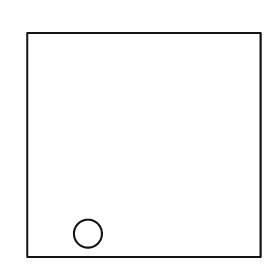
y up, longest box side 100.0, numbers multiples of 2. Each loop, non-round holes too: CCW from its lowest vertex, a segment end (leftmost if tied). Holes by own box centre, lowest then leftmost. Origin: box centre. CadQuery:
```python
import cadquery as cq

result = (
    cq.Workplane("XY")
    .moveTo(-50.0, -48.0)
    .lineTo(50.0, -48.0)
    .lineTo(50.0, 48.0)
    .lineTo(-50.0, 48.0)
    .close()
    .moveTo(-24.0, -38.0)
    .circle(6.0)
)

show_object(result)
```